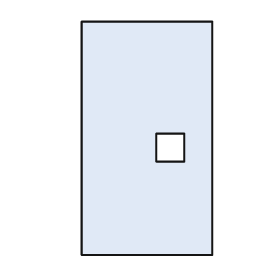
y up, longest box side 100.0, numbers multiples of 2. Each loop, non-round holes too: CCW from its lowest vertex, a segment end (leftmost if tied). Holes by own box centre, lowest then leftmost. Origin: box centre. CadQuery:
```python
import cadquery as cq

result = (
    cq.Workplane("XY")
    .moveTo(-28.0, -50.0)
    .lineTo(28.0, -50.0)
    .lineTo(28.0, 50.0)
    .lineTo(-28.0, 50.0)
    .close()
    .moveTo(4.0, -10.0)
    .lineTo(16.0, -10.0)
    .lineTo(16.0, 2.0)
    .lineTo(4.0, 2.0)
    .close()
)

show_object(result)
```